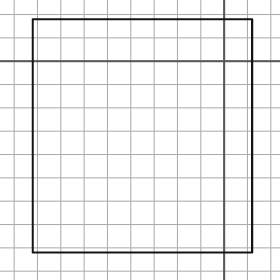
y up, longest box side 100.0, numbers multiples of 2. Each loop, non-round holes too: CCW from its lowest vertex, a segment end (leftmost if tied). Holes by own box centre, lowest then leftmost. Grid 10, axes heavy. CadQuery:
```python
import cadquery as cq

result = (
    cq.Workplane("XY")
    .moveTo(-82.0, -82.0)
    .lineTo(12.0, -82.0)
    .lineTo(12.0, 18.0)
    .lineTo(-82.0, 18.0)
    .close()
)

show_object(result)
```